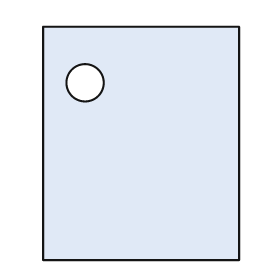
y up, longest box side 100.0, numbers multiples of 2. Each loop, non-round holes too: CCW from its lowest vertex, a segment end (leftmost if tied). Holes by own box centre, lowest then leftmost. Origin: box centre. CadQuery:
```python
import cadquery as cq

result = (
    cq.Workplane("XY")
    .moveTo(-42.0, -50.0)
    .lineTo(42.0, -50.0)
    .lineTo(42.0, 50.0)
    .lineTo(-42.0, 50.0)
    .close()
    .moveTo(-24.0, 26.0)
    .circle(8.0)
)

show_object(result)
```